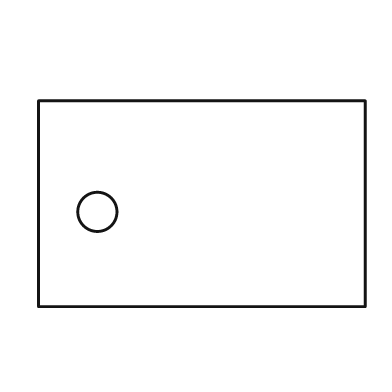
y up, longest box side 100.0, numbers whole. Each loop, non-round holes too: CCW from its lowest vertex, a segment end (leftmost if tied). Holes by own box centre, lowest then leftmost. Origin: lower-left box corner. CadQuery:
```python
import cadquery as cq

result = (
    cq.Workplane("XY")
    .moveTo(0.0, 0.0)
    .lineTo(100.0, 0.0)
    .lineTo(100.0, 63.0)
    .lineTo(0.0, 63.0)
    .close()
    .moveTo(18.0, 29.0)
    .circle(6.0)
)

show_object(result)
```